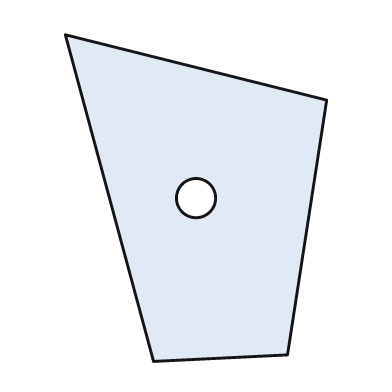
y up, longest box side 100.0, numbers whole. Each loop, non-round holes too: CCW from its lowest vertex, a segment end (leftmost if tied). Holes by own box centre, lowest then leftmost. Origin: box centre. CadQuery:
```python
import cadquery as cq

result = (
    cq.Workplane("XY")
    .moveTo(-13.0, -50.0)
    .lineTo(28.0, -48.0)
    .lineTo(40.0, 30.0)
    .lineTo(-40.0, 50.0)
    .close()
    .moveTo(0.0, 0.0)
    .circle(6.0)
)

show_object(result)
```